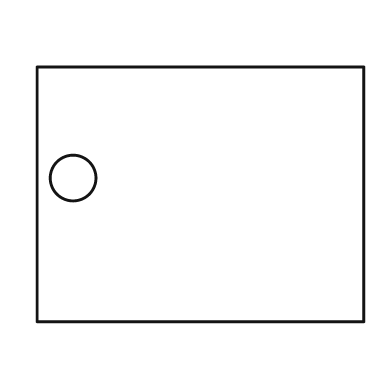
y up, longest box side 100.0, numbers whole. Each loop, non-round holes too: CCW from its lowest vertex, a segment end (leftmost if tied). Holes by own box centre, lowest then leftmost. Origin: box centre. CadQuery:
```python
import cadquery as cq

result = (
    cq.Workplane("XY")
    .moveTo(-50.0, -39.0)
    .lineTo(50.0, -39.0)
    .lineTo(50.0, 39.0)
    .lineTo(-50.0, 39.0)
    .close()
    .moveTo(-39.0, 5.0)
    .circle(7.0)
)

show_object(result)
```